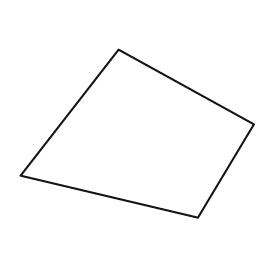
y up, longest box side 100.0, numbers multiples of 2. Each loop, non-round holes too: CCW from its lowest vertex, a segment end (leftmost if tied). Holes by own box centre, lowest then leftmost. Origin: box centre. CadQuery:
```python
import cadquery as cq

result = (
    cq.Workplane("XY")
    .moveTo(26.0, -36.0)
    .lineTo(50.0, 4.0)
    .lineTo(-8.0, 36.0)
    .lineTo(-50.0, -18.0)
    .close()
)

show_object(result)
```